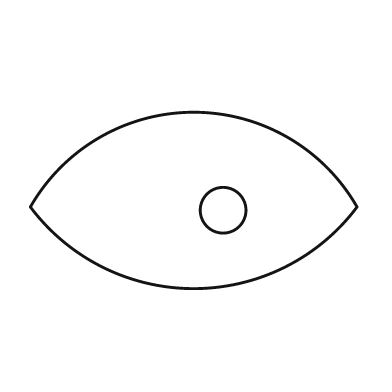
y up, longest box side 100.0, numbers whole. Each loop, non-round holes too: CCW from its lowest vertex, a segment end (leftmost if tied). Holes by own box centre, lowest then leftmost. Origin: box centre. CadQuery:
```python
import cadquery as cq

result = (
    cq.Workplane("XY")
    .moveTo(-50.0, -2.0)
    .threePointArc((0.0, -27.0), (50.0, -2.0))
    .threePointArc((0.0, 27.0), (-50.0, -2.0))
    .close()
    .moveTo(9.0, -3.0)
    .circle(7.0)
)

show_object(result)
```